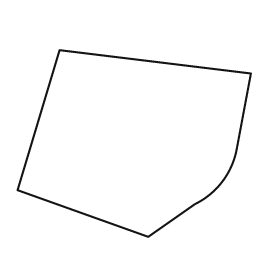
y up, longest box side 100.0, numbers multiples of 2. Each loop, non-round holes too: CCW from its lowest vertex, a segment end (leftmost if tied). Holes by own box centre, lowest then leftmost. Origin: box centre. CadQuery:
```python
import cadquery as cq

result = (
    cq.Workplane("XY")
    .moveTo(6.0, -40.0)
    .lineTo(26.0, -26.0)
    .threePointArc((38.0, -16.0), (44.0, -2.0))
    .lineTo(50.0, 30.0)
    .lineTo(-32.0, 40.0)
    .lineTo(-50.0, -20.0)
    .close()
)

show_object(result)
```